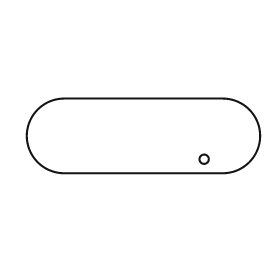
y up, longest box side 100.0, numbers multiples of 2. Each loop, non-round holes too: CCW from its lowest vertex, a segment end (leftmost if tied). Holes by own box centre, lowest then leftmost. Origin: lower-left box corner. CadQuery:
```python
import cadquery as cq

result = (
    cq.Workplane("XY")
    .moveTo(16.0, 0.0)
    .lineTo(84.0, 0.0)
    .threePointArc((100.0, 16.0), (84.0, 32.0))
    .lineTo(16.0, 32.0)
    .threePointArc((0.0, 16.0), (16.0, 0.0))
    .close()
    .moveTo(76.0, 6.0)
    .circle(2.0)
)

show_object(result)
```